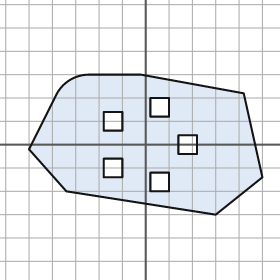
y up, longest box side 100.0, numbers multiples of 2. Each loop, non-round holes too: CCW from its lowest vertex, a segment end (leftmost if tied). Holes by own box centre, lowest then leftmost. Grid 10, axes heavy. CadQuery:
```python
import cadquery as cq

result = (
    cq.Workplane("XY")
    .moveTo(30.0, -30.0)
    .lineTo(50.0, -14.0)
    .lineTo(42.0, 22.0)
    .lineTo(-2.0, 30.0)
    .lineTo(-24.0, 30.0)
    .threePointArc((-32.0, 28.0), (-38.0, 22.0))
    .lineTo(-50.0, -2.0)
    .lineTo(-34.0, -20.0)
    .close()
    .moveTo(2.0, -20.0)
    .lineTo(10.0, -20.0)
    .lineTo(10.0, -12.0)
    .lineTo(2.0, -12.0)
    .close()
    .moveTo(-18.0, -14.0)
    .lineTo(-10.0, -14.0)
    .lineTo(-10.0, -6.0)
    .lineTo(-18.0, -6.0)
    .close()
    .moveTo(14.0, -4.0)
    .lineTo(22.0, -4.0)
    .lineTo(22.0, 4.0)
    .lineTo(14.0, 4.0)
    .close()
    .moveTo(-18.0, 6.0)
    .lineTo(-10.0, 6.0)
    .lineTo(-10.0, 14.0)
    .lineTo(-18.0, 14.0)
    .close()
    .moveTo(2.0, 12.0)
    .lineTo(10.0, 12.0)
    .lineTo(10.0, 20.0)
    .lineTo(2.0, 20.0)
    .close()
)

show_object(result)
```